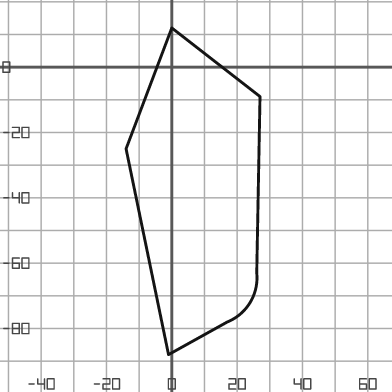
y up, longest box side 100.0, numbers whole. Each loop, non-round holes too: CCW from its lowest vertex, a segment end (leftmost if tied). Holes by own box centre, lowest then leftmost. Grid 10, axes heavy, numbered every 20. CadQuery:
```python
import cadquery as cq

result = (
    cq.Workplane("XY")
    .moveTo(-1.0, -88.0)
    .lineTo(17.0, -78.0)
    .threePointArc((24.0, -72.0), (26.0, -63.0))
    .lineTo(27.0, -9.0)
    .lineTo(0.0, 12.0)
    .lineTo(-14.0, -25.0)
    .close()
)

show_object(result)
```